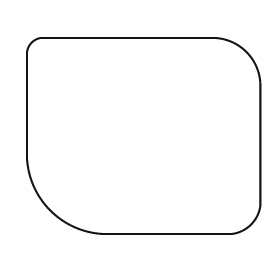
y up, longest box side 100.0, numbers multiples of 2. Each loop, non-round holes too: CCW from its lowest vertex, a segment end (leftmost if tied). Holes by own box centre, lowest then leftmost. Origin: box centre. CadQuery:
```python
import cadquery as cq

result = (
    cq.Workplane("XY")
    .moveTo(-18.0, -42.0)
    .lineTo(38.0, -42.0)
    .threePointArc((46.0, -38.0), (50.0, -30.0))
    .lineTo(50.0, 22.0)
    .threePointArc((44.0, 36.0), (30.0, 42.0))
    .lineTo(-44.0, 42.0)
    .threePointArc((-48.0, 40.0), (-50.0, 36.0))
    .lineTo(-50.0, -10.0)
    .threePointArc((-40.0, -32.0), (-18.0, -42.0))
    .close()
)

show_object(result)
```